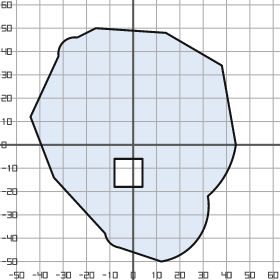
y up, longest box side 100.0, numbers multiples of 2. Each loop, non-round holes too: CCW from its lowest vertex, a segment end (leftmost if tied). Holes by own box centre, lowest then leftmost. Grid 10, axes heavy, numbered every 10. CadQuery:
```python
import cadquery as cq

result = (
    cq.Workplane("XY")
    .moveTo(12.0, -50.0)
    .threePointArc((28.0, -40.0), (32.0, -22.0))
    .threePointArc((40.0, -12.0), (44.0, 0.0))
    .lineTo(38.0, 34.0)
    .lineTo(14.0, 48.0)
    .lineTo(-16.0, 50.0)
    .lineTo(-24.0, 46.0)
    .threePointArc((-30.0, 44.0), (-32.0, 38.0))
    .lineTo(-44.0, 12.0)
    .lineTo(-34.0, -14.0)
    .lineTo(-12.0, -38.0)
    .threePointArc((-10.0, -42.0), (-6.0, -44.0))
    .close()
    .moveTo(-8.0, -18.0)
    .lineTo(4.0, -18.0)
    .lineTo(4.0, -6.0)
    .lineTo(-8.0, -6.0)
    .close()
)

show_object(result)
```